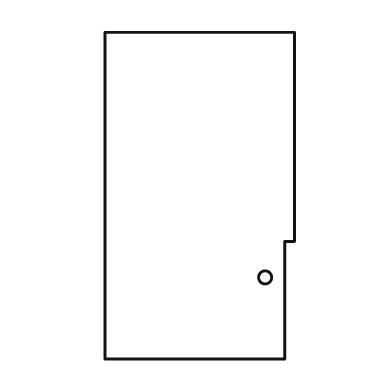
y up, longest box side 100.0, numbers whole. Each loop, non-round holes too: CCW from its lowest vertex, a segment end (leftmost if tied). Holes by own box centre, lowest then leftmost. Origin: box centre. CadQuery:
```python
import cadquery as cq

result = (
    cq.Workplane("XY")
    .moveTo(-29.0, -50.0)
    .lineTo(26.0, -50.0)
    .lineTo(26.0, -14.0)
    .lineTo(29.0, -14.0)
    .lineTo(29.0, 50.0)
    .lineTo(-29.0, 50.0)
    .close()
    .moveTo(20.0, -25.0)
    .circle(2.0)
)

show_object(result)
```